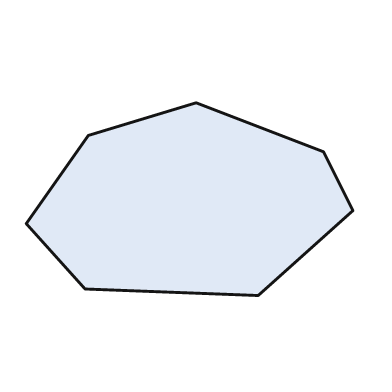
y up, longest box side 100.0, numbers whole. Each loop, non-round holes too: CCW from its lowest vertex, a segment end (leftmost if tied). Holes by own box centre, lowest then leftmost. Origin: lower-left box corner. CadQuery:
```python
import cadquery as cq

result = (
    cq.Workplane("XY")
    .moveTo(71.0, 0.0)
    .lineTo(100.0, 26.0)
    .lineTo(91.0, 44.0)
    .lineTo(52.0, 59.0)
    .lineTo(19.0, 49.0)
    .lineTo(0.0, 22.0)
    .lineTo(18.0, 2.0)
    .close()
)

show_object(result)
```